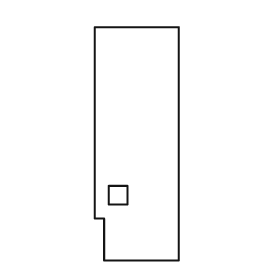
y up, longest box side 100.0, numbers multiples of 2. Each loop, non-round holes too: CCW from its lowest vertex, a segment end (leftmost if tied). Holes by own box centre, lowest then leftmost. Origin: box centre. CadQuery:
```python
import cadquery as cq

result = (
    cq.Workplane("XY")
    .moveTo(-14.0, -50.0)
    .lineTo(18.0, -50.0)
    .lineTo(18.0, 50.0)
    .lineTo(-18.0, 50.0)
    .lineTo(-18.0, -32.0)
    .lineTo(-14.0, -32.0)
    .close()
    .moveTo(-12.0, -26.0)
    .lineTo(-4.0, -26.0)
    .lineTo(-4.0, -18.0)
    .lineTo(-12.0, -18.0)
    .close()
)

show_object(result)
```